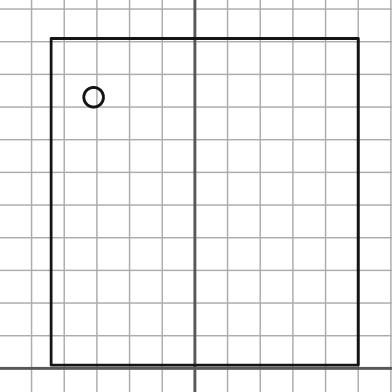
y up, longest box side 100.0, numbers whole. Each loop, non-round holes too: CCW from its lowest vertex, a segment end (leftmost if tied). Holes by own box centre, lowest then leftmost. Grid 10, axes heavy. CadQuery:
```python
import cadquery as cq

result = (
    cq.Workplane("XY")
    .moveTo(-44.0, 1.0)
    .lineTo(50.0, 1.0)
    .lineTo(50.0, 101.0)
    .lineTo(-44.0, 101.0)
    .close()
    .moveTo(-31.0, 83.0)
    .circle(3.0)
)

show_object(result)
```